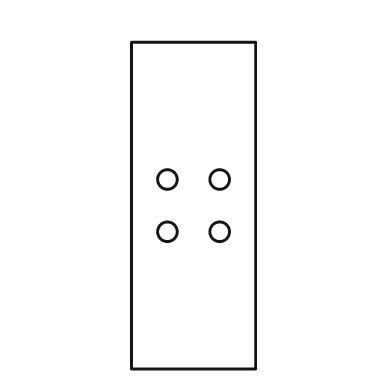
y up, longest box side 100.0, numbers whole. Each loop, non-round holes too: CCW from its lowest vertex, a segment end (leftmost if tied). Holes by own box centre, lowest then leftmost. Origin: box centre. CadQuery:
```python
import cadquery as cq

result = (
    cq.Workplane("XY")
    .moveTo(-19.0, -50.0)
    .lineTo(19.0, -50.0)
    .lineTo(19.0, 50.0)
    .lineTo(-19.0, 50.0)
    .close()
    .moveTo(-8.0, -8.0)
    .circle(3.0)
    .moveTo(8.0, -8.0)
    .circle(3.0)
    .moveTo(-8.0, 8.0)
    .circle(3.0)
    .moveTo(8.0, 8.0)
    .circle(3.0)
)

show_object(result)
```